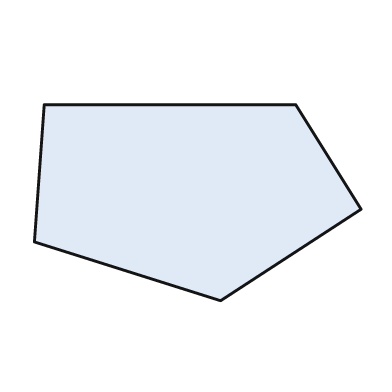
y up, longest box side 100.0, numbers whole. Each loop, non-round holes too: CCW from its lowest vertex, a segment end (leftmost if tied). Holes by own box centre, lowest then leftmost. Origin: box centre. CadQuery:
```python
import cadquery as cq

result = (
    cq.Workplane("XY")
    .moveTo(7.0, -30.0)
    .lineTo(50.0, -2.0)
    .lineTo(30.0, 30.0)
    .lineTo(-47.0, 30.0)
    .lineTo(-50.0, -12.0)
    .close()
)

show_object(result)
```